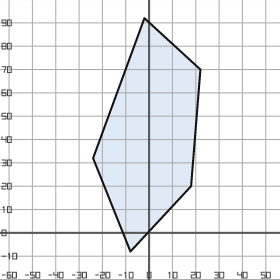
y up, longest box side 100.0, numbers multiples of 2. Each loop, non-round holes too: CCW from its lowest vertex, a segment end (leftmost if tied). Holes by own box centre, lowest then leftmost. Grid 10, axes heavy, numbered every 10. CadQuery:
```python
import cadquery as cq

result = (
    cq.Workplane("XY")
    .moveTo(-8.0, -8.0)
    .lineTo(18.0, 20.0)
    .lineTo(22.0, 70.0)
    .lineTo(-2.0, 92.0)
    .lineTo(-24.0, 32.0)
    .close()
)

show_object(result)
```